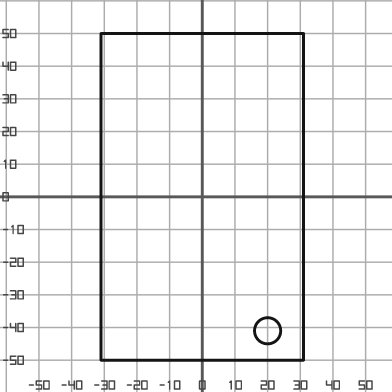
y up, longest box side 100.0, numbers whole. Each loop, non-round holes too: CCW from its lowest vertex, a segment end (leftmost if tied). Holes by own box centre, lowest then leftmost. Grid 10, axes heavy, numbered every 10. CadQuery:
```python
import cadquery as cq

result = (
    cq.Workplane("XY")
    .moveTo(-31.0, -50.0)
    .lineTo(31.0, -50.0)
    .lineTo(31.0, 50.0)
    .lineTo(-31.0, 50.0)
    .close()
    .moveTo(20.0, -41.0)
    .circle(4.0)
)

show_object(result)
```